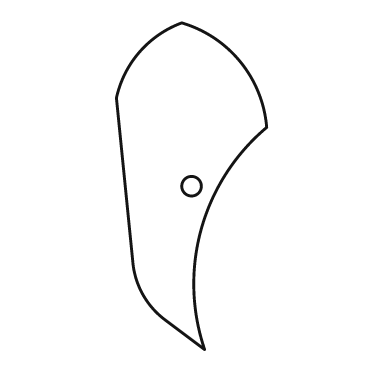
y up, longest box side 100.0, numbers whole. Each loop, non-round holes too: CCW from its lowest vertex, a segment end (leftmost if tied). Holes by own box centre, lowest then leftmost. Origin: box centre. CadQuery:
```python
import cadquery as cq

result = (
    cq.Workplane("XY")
    .moveTo(4.0, -50.0)
    .threePointArc((3.0, -13.0), (23.0, 18.0))
    .threePointArc((15.0, 38.0), (-3.0, 50.0))
    .threePointArc((-16.0, 41.0), (-23.0, 27.0))
    .lineTo(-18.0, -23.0)
    .threePointArc((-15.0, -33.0), (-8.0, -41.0))
    .close()
    .moveTo(0.0, 0.0)
    .circle(3.0)
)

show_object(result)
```